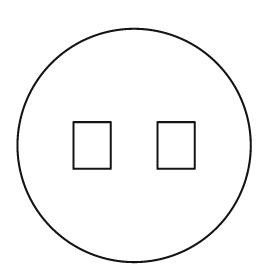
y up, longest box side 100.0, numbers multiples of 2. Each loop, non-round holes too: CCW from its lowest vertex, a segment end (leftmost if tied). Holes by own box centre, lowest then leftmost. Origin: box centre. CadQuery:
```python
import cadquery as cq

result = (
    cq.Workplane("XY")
    .moveTo(0.0, 0.0)
    .circle(50.0)
    .moveTo(-26.0, -10.0)
    .lineTo(-10.0, -10.0)
    .lineTo(-10.0, 10.0)
    .lineTo(-26.0, 10.0)
    .close()
    .moveTo(10.0, -10.0)
    .lineTo(26.0, -10.0)
    .lineTo(26.0, 10.0)
    .lineTo(10.0, 10.0)
    .close()
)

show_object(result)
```